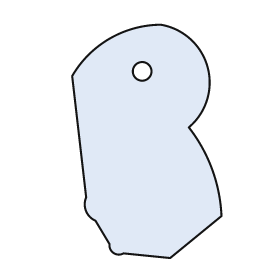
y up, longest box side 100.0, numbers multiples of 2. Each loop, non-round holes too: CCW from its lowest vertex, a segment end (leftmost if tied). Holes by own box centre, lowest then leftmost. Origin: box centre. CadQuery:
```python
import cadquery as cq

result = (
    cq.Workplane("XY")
    .moveTo(10.0, -50.0)
    .lineTo(32.0, -32.0)
    .threePointArc((28.0, -12.0), (18.0, 6.0))
    .threePointArc((26.0, 32.0), (6.0, 50.0))
    .threePointArc((-16.0, 44.0), (-32.0, 28.0))
    .lineTo(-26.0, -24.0)
    .threePointArc((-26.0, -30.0), (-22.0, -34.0))
    .lineTo(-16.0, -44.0)
    .threePointArc((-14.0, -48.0), (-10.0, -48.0))
    .close()
    .moveTo(-2.0, 30.0)
    .circle(4.0)
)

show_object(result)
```